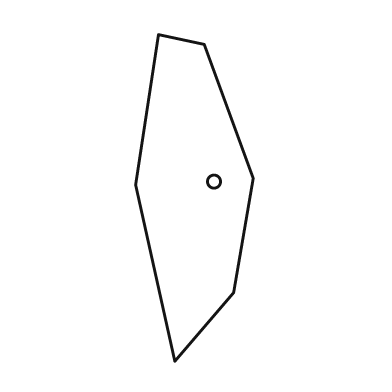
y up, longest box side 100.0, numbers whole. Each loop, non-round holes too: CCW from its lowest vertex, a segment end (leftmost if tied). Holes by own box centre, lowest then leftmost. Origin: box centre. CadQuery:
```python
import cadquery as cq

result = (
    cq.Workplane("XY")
    .moveTo(-6.0, -50.0)
    .lineTo(12.0, -29.0)
    .lineTo(18.0, 6.0)
    .lineTo(3.0, 47.0)
    .lineTo(-11.0, 50.0)
    .lineTo(-18.0, 4.0)
    .close()
    .moveTo(6.0, 5.0)
    .circle(2.0)
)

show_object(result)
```